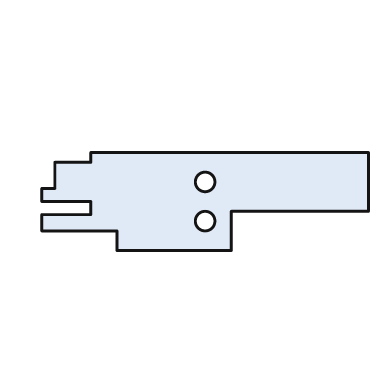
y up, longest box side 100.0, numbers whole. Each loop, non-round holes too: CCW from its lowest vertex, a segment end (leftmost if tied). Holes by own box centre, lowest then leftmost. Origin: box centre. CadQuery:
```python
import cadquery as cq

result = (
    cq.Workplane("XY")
    .moveTo(-27.0, -15.0)
    .lineTo(8.0, -15.0)
    .lineTo(8.0, -3.0)
    .lineTo(50.0, -3.0)
    .lineTo(50.0, 15.0)
    .lineTo(-35.0, 15.0)
    .lineTo(-35.0, 12.0)
    .lineTo(-46.0, 12.0)
    .lineTo(-46.0, 4.0)
    .lineTo(-50.0, 4.0)
    .lineTo(-50.0, 0.0)
    .lineTo(-35.0, 0.0)
    .lineTo(-35.0, -4.0)
    .lineTo(-50.0, -4.0)
    .lineTo(-50.0, -9.0)
    .lineTo(-27.0, -9.0)
    .close()
    .moveTo(0.0, -6.0)
    .circle(3.0)
    .moveTo(0.0, 6.0)
    .circle(3.0)
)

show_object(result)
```